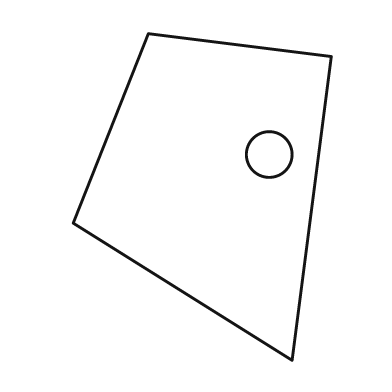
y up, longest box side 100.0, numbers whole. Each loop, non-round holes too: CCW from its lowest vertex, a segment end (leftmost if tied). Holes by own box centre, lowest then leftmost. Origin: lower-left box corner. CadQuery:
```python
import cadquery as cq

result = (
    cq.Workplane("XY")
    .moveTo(67.0, 0.0)
    .lineTo(79.0, 93.0)
    .lineTo(23.0, 100.0)
    .lineTo(0.0, 42.0)
    .close()
    .moveTo(60.0, 63.0)
    .circle(7.0)
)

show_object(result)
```